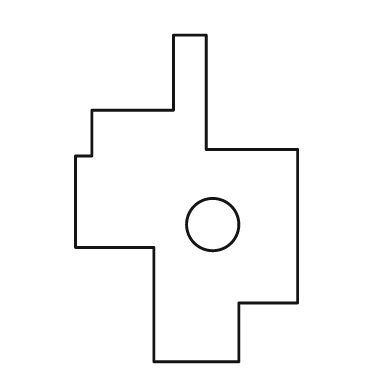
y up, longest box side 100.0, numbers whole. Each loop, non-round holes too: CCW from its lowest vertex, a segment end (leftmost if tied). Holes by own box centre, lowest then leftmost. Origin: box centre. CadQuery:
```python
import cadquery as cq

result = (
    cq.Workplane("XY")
    .moveTo(-10.0, -50.0)
    .lineTo(16.0, -50.0)
    .lineTo(16.0, -32.0)
    .lineTo(34.0, -32.0)
    .lineTo(34.0, 15.0)
    .lineTo(6.0, 15.0)
    .lineTo(6.0, 50.0)
    .lineTo(-4.0, 50.0)
    .lineTo(-4.0, 27.0)
    .lineTo(-29.0, 27.0)
    .lineTo(-29.0, 13.0)
    .lineTo(-34.0, 13.0)
    .lineTo(-34.0, -15.0)
    .lineTo(-10.0, -15.0)
    .close()
    .moveTo(8.0, -8.0)
    .circle(8.0)
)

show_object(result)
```